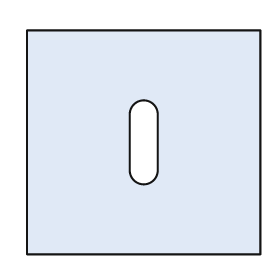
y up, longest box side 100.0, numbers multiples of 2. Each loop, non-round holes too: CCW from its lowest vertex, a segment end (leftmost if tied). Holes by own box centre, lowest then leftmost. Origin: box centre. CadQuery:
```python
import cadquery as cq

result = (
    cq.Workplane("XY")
    .moveTo(-50.0, -48.0)
    .lineTo(50.0, -48.0)
    .lineTo(50.0, 48.0)
    .lineTo(-50.0, 48.0)
    .close()
    .moveTo(-6.0, -12.0)
    .threePointArc((0.0, -18.0), (6.0, -12.0))
    .lineTo(6.0, 12.0)
    .threePointArc((0.0, 18.0), (-6.0, 12.0))
    .close()
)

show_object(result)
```